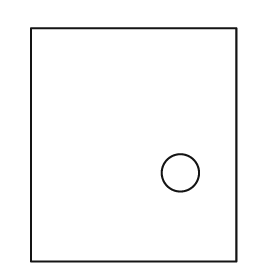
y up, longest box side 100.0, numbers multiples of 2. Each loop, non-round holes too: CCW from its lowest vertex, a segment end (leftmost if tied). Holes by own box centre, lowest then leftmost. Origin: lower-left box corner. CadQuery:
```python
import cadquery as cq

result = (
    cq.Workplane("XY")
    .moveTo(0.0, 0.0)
    .lineTo(88.0, 0.0)
    .lineTo(88.0, 100.0)
    .lineTo(0.0, 100.0)
    .close()
    .moveTo(64.0, 38.0)
    .circle(8.0)
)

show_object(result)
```